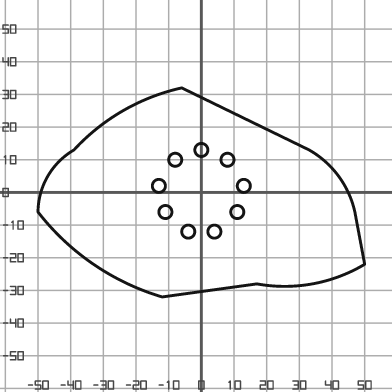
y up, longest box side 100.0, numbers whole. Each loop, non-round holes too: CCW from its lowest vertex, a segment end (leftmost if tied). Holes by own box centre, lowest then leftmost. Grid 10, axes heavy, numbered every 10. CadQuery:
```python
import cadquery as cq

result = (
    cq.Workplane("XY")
    .moveTo(-12.0, -32.0)
    .lineTo(17.0, -28.0)
    .threePointArc((34.0, -28.0), (50.0, -22.0))
    .lineTo(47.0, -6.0)
    .threePointArc((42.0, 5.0), (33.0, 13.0))
    .lineTo(-6.0, 32.0)
    .threePointArc((-24.0, 25.0), (-39.0, 13.0))
    .threePointArc((-47.0, 5.0), (-50.0, -6.0))
    .threePointArc((-33.0, -22.0), (-12.0, -32.0))
    .close()
    .moveTo(-4.0, -12.0)
    .circle(2.0)
    .moveTo(4.0, -12.0)
    .circle(2.0)
    .moveTo(-11.0, -6.0)
    .circle(2.0)
    .moveTo(11.0, -6.0)
    .circle(2.0)
    .moveTo(-13.0, 2.0)
    .circle(2.0)
    .moveTo(13.0, 2.0)
    .circle(2.0)
    .moveTo(-8.0, 10.0)
    .circle(2.0)
    .moveTo(8.0, 10.0)
    .circle(2.0)
    .moveTo(0.0, 13.0)
    .circle(2.0)
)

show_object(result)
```